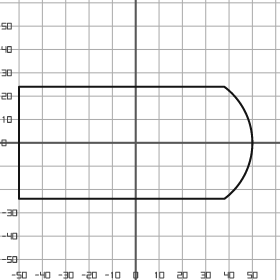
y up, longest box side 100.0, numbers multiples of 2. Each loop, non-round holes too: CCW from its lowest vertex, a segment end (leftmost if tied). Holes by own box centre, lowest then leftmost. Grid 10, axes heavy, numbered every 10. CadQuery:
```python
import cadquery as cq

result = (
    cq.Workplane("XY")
    .moveTo(-50.0, -24.0)
    .lineTo(38.0, -24.0)
    .threePointArc((50.0, 0.0), (38.0, 24.0))
    .lineTo(-50.0, 24.0)
    .close()
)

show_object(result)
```